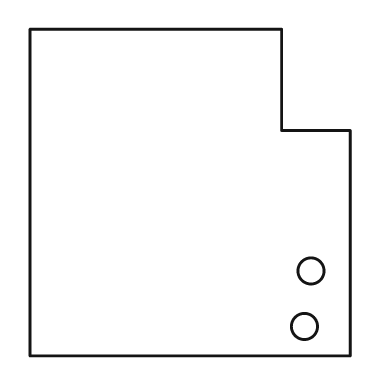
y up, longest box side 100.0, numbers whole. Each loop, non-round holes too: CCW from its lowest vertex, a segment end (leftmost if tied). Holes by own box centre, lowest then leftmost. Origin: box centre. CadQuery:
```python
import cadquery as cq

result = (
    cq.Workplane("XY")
    .moveTo(-49.0, -50.0)
    .lineTo(49.0, -50.0)
    .lineTo(49.0, 19.0)
    .lineTo(28.0, 19.0)
    .lineTo(28.0, 50.0)
    .lineTo(-49.0, 50.0)
    .close()
    .moveTo(35.0, -41.0)
    .circle(4.0)
    .moveTo(37.0, -24.0)
    .circle(4.0)
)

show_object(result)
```